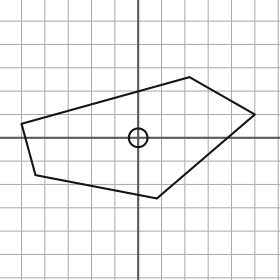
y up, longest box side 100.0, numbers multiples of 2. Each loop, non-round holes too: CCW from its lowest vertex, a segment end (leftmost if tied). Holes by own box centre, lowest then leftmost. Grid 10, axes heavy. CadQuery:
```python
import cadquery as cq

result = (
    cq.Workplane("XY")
    .moveTo(8.0, -26.0)
    .lineTo(50.0, 10.0)
    .lineTo(22.0, 26.0)
    .lineTo(-50.0, 6.0)
    .lineTo(-44.0, -16.0)
    .close()
    .moveTo(0.0, 0.0)
    .circle(4.0)
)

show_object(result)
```